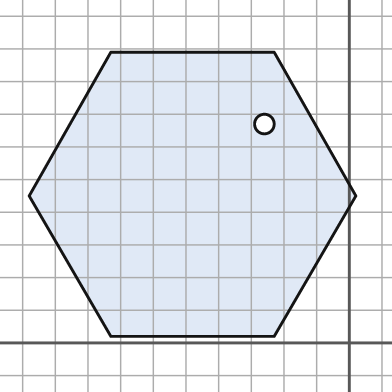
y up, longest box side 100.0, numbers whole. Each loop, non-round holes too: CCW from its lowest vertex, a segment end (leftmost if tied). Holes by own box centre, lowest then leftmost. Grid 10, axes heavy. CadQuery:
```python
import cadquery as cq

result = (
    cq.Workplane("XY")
    .moveTo(-73.0, 2.0)
    .lineTo(-23.0, 2.0)
    .lineTo(2.0, 45.0)
    .lineTo(-23.0, 89.0)
    .lineTo(-73.0, 89.0)
    .lineTo(-98.0, 45.0)
    .close()
    .moveTo(-26.0, 67.0)
    .circle(3.0)
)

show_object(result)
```